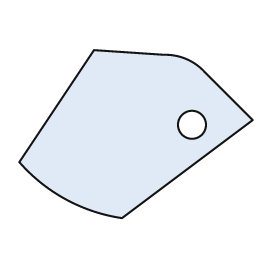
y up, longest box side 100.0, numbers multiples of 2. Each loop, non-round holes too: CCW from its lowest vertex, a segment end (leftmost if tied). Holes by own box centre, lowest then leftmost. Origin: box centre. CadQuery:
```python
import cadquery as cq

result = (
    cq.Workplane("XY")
    .moveTo(-6.0, -36.0)
    .lineTo(50.0, 6.0)
    .lineTo(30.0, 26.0)
    .threePointArc((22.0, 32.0), (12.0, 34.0))
    .lineTo(-18.0, 36.0)
    .lineTo(-50.0, -12.0)
    .threePointArc((-30.0, -28.0), (-6.0, -36.0))
    .close()
    .moveTo(24.0, 4.0)
    .circle(6.0)
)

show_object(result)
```